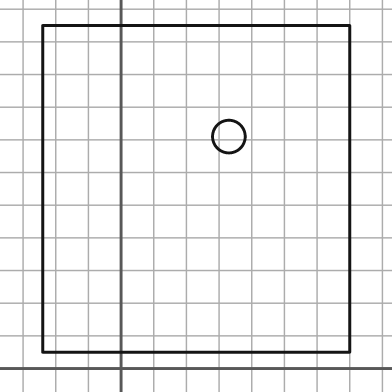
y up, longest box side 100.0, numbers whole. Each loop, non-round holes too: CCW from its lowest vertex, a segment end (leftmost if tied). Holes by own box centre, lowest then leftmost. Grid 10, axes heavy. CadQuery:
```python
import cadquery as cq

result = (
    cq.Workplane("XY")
    .moveTo(-24.0, 5.0)
    .lineTo(70.0, 5.0)
    .lineTo(70.0, 105.0)
    .lineTo(-24.0, 105.0)
    .close()
    .moveTo(33.0, 71.0)
    .circle(5.0)
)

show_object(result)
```